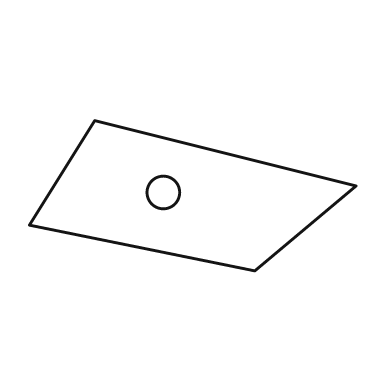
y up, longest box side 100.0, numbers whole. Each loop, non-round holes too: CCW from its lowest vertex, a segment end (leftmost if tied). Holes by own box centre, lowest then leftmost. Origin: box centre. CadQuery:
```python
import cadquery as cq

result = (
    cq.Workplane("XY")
    .moveTo(19.0, -23.0)
    .lineTo(50.0, 3.0)
    .lineTo(-30.0, 23.0)
    .lineTo(-50.0, -9.0)
    .close()
    .moveTo(-9.0, 1.0)
    .circle(5.0)
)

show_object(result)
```